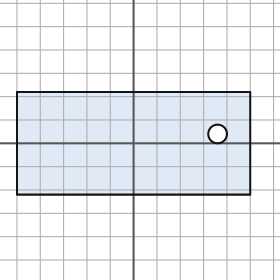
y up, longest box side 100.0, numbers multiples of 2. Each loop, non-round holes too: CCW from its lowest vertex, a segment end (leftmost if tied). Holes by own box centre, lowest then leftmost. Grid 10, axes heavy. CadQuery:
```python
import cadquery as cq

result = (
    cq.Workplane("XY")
    .moveTo(-50.0, -22.0)
    .lineTo(50.0, -22.0)
    .lineTo(50.0, 22.0)
    .lineTo(-50.0, 22.0)
    .close()
    .moveTo(36.0, 4.0)
    .circle(4.0)
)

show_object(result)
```